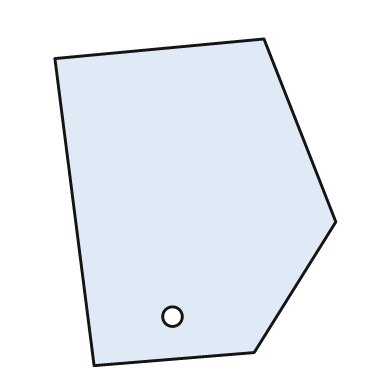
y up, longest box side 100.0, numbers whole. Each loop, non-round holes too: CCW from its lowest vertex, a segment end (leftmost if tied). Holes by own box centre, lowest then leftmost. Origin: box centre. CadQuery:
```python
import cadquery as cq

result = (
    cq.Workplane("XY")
    .moveTo(-31.0, -50.0)
    .lineTo(18.0, -46.0)
    .lineTo(43.0, -6.0)
    .lineTo(21.0, 50.0)
    .lineTo(-43.0, 44.0)
    .close()
    .moveTo(-7.0, -35.0)
    .circle(3.0)
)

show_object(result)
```